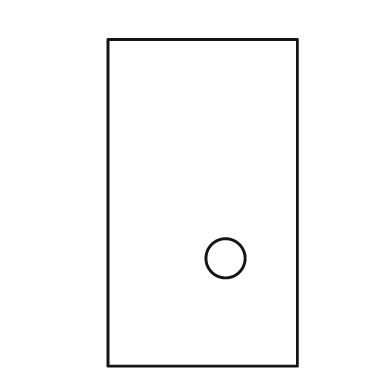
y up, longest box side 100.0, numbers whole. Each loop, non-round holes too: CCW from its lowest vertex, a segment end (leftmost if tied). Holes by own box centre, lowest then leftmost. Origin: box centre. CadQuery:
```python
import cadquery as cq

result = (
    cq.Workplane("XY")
    .moveTo(-29.0, -50.0)
    .lineTo(29.0, -50.0)
    .lineTo(29.0, 50.0)
    .lineTo(-29.0, 50.0)
    .close()
    .moveTo(7.0, -17.0)
    .circle(6.0)
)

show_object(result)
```